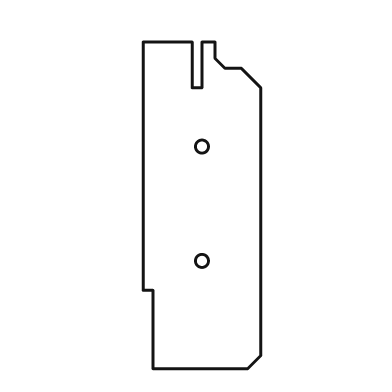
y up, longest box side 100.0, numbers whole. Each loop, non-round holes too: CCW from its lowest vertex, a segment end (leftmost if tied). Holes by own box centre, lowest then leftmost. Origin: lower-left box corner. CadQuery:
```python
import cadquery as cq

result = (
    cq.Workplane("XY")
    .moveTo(3.0, 0.0)
    .lineTo(32.0, 0.0)
    .lineTo(36.0, 4.0)
    .lineTo(36.0, 86.0)
    .lineTo(30.0, 92.0)
    .lineTo(25.0, 92.0)
    .lineTo(22.0, 95.0)
    .lineTo(22.0, 100.0)
    .lineTo(18.0, 100.0)
    .lineTo(18.0, 86.0)
    .lineTo(15.0, 86.0)
    .lineTo(15.0, 100.0)
    .lineTo(0.0, 100.0)
    .lineTo(0.0, 24.0)
    .lineTo(3.0, 24.0)
    .close()
    .moveTo(18.0, 33.0)
    .circle(2.0)
    .moveTo(18.0, 68.0)
    .circle(2.0)
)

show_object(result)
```